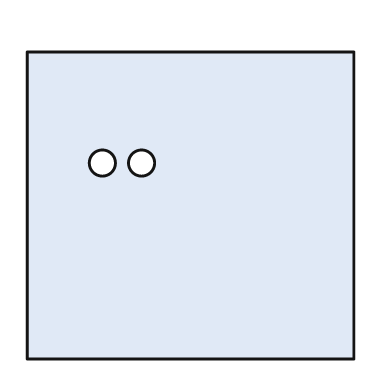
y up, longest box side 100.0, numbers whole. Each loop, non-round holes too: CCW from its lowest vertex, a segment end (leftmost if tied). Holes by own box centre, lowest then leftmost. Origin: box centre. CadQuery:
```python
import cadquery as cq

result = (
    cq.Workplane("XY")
    .moveTo(-50.0, -47.0)
    .lineTo(50.0, -47.0)
    .lineTo(50.0, 47.0)
    .lineTo(-50.0, 47.0)
    .close()
    .moveTo(-27.0, 13.0)
    .circle(4.0)
    .moveTo(-15.0, 13.0)
    .circle(4.0)
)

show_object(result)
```